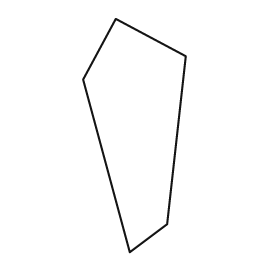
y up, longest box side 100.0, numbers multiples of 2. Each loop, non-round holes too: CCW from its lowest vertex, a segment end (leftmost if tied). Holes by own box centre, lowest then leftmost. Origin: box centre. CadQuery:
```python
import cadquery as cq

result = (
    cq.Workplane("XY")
    .moveTo(-2.0, -50.0)
    .lineTo(14.0, -38.0)
    .lineTo(22.0, 34.0)
    .lineTo(-8.0, 50.0)
    .lineTo(-22.0, 24.0)
    .close()
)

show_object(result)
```